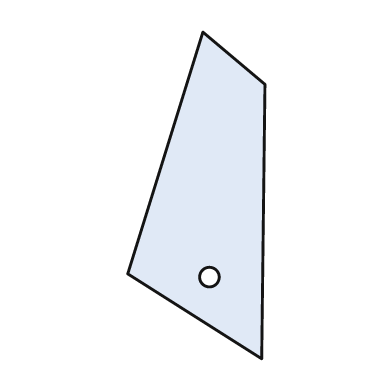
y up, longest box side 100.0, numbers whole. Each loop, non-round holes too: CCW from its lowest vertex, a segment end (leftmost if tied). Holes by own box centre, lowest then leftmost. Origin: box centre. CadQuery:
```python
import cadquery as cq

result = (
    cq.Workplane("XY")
    .moveTo(20.0, -50.0)
    .lineTo(21.0, 34.0)
    .lineTo(2.0, 50.0)
    .lineTo(-21.0, -24.0)
    .close()
    .moveTo(4.0, -25.0)
    .circle(3.0)
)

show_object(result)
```